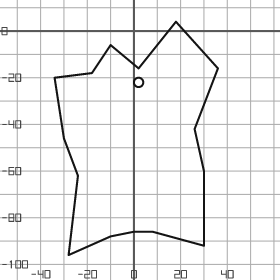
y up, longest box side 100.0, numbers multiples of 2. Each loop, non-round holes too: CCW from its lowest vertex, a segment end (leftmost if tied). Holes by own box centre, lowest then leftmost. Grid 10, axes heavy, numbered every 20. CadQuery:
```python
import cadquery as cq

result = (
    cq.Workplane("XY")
    .moveTo(-28.0, -96.0)
    .lineTo(-10.0, -88.0)
    .lineTo(0.0, -86.0)
    .lineTo(8.0, -86.0)
    .lineTo(30.0, -92.0)
    .lineTo(30.0, -60.0)
    .lineTo(26.0, -42.0)
    .lineTo(36.0, -16.0)
    .lineTo(18.0, 4.0)
    .lineTo(2.0, -16.0)
    .lineTo(-10.0, -6.0)
    .lineTo(-18.0, -18.0)
    .lineTo(-34.0, -20.0)
    .lineTo(-30.0, -46.0)
    .lineTo(-24.0, -62.0)
    .close()
    .moveTo(2.0, -22.0)
    .circle(2.0)
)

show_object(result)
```